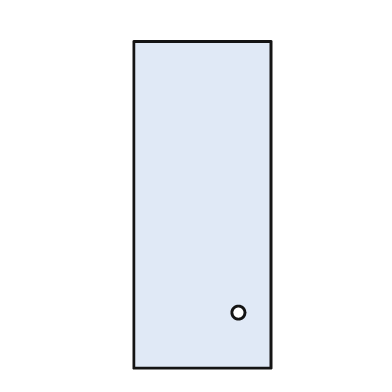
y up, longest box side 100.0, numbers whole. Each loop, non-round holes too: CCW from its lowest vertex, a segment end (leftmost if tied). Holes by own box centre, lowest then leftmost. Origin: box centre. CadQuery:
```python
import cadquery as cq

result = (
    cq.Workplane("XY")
    .moveTo(-21.0, -50.0)
    .lineTo(21.0, -50.0)
    .lineTo(21.0, 50.0)
    .lineTo(-21.0, 50.0)
    .close()
    .moveTo(11.0, -33.0)
    .circle(2.0)
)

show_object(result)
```